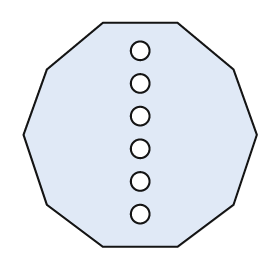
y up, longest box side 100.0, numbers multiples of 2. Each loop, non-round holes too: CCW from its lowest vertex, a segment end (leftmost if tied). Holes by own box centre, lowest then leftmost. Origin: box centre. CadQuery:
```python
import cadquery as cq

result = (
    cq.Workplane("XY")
    .moveTo(-16.0, -48.0)
    .lineTo(16.0, -48.0)
    .lineTo(40.0, -30.0)
    .lineTo(50.0, 0.0)
    .lineTo(40.0, 28.0)
    .lineTo(16.0, 48.0)
    .lineTo(-16.0, 48.0)
    .lineTo(-40.0, 28.0)
    .lineTo(-50.0, 0.0)
    .lineTo(-40.0, -30.0)
    .close()
    .moveTo(0.0, -34.0)
    .circle(4.0)
    .moveTo(0.0, -20.0)
    .circle(4.0)
    .moveTo(0.0, -6.0)
    .circle(4.0)
    .moveTo(0.0, 8.0)
    .circle(4.0)
    .moveTo(0.0, 22.0)
    .circle(4.0)
    .moveTo(0.0, 36.0)
    .circle(4.0)
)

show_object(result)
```